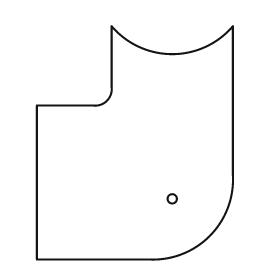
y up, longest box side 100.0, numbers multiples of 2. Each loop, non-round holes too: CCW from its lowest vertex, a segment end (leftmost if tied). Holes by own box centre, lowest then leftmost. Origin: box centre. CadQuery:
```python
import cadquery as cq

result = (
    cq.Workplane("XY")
    .moveTo(-42.0, -50.0)
    .lineTo(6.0, -50.0)
    .threePointArc((32.0, -40.0), (42.0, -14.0))
    .lineTo(42.0, 50.0)
    .threePointArc((16.0, 38.0), (-10.0, 50.0))
    .lineTo(-10.0, 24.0)
    .threePointArc((-12.0, 18.0), (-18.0, 16.0))
    .lineTo(-42.0, 16.0)
    .close()
    .moveTo(16.0, -24.0)
    .circle(2.0)
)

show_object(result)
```